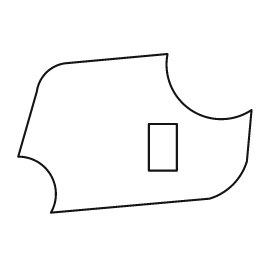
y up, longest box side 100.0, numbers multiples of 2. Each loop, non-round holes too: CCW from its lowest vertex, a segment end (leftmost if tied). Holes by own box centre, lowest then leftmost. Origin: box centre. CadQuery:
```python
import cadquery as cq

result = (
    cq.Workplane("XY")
    .moveTo(-36.0, -34.0)
    .lineTo(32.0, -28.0)
    .threePointArc((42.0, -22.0), (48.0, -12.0))
    .lineTo(50.0, 10.0)
    .threePointArc((24.0, 10.0), (14.0, 34.0))
    .lineTo(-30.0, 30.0)
    .threePointArc((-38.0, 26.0), (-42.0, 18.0))
    .lineTo(-50.0, -10.0)
    .threePointArc((-36.0, -18.0), (-36.0, -34.0))
    .close()
    .moveTo(6.0, -16.0)
    .lineTo(18.0, -16.0)
    .lineTo(18.0, 4.0)
    .lineTo(6.0, 4.0)
    .close()
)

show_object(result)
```